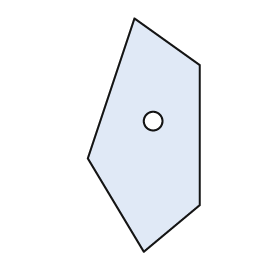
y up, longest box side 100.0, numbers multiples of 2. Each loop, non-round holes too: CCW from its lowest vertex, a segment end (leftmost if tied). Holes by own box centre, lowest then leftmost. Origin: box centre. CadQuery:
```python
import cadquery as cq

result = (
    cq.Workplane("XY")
    .moveTo(0.0, -50.0)
    .lineTo(24.0, -30.0)
    .lineTo(24.0, 30.0)
    .lineTo(-4.0, 50.0)
    .lineTo(-24.0, -10.0)
    .close()
    .moveTo(4.0, 6.0)
    .circle(4.0)
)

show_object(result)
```